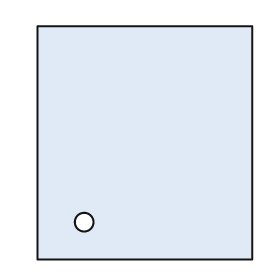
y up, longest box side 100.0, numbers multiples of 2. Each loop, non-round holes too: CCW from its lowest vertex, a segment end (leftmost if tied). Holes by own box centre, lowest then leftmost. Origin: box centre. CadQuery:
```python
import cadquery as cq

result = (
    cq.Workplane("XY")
    .moveTo(-46.0, -50.0)
    .lineTo(46.0, -50.0)
    .lineTo(46.0, 50.0)
    .lineTo(-46.0, 50.0)
    .close()
    .moveTo(-26.0, -34.0)
    .circle(4.0)
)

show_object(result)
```